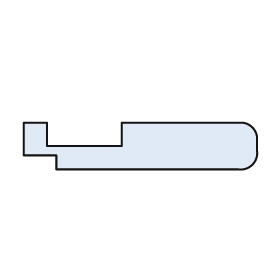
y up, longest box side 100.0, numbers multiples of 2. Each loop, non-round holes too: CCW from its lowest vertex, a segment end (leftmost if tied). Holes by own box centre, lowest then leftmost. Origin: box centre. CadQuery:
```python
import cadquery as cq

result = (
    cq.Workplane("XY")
    .moveTo(-36.0, -10.0)
    .lineTo(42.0, -10.0)
    .threePointArc((48.0, -8.0), (50.0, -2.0))
    .lineTo(50.0, 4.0)
    .threePointArc((48.0, 8.0), (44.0, 10.0))
    .lineTo(-8.0, 10.0)
    .lineTo(-8.0, 0.0)
    .lineTo(-40.0, 0.0)
    .lineTo(-40.0, 10.0)
    .lineTo(-50.0, 10.0)
    .lineTo(-50.0, -4.0)
    .lineTo(-36.0, -4.0)
    .close()
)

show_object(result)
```